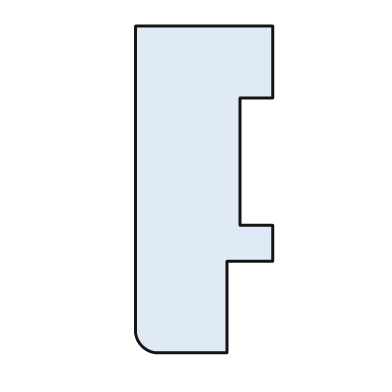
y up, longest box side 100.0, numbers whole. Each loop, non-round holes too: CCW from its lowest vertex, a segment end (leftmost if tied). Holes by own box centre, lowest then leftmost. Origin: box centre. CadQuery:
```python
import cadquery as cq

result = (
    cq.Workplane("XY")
    .moveTo(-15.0, -50.0)
    .lineTo(7.0, -50.0)
    .lineTo(7.0, -22.0)
    .lineTo(21.0, -22.0)
    .lineTo(21.0, -11.0)
    .lineTo(11.0, -11.0)
    .lineTo(11.0, 28.0)
    .lineTo(21.0, 28.0)
    .lineTo(21.0, 50.0)
    .lineTo(-21.0, 50.0)
    .lineTo(-21.0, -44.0)
    .threePointArc((-19.0, -48.0), (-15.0, -50.0))
    .close()
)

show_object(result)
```